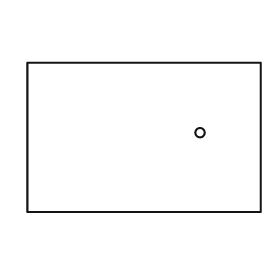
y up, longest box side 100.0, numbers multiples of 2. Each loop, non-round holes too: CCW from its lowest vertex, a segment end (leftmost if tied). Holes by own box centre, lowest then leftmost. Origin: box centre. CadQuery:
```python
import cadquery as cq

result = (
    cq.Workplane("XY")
    .moveTo(-50.0, -32.0)
    .lineTo(50.0, -32.0)
    .lineTo(50.0, 32.0)
    .lineTo(-50.0, 32.0)
    .close()
    .moveTo(24.0, 2.0)
    .circle(2.0)
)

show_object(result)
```